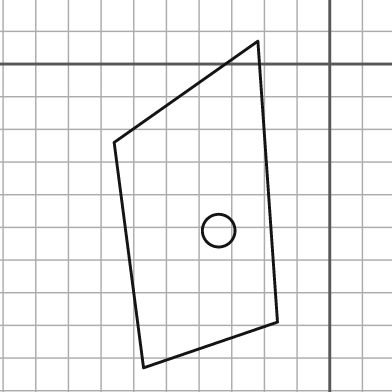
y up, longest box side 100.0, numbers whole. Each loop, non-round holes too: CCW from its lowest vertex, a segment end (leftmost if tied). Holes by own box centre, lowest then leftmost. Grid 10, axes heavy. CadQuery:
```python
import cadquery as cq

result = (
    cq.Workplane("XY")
    .moveTo(-57.0, -93.0)
    .lineTo(-16.0, -79.0)
    .lineTo(-22.0, 7.0)
    .lineTo(-66.0, -24.0)
    .close()
    .moveTo(-34.0, -51.0)
    .circle(5.0)
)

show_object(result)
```